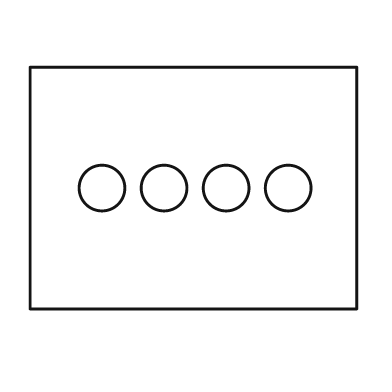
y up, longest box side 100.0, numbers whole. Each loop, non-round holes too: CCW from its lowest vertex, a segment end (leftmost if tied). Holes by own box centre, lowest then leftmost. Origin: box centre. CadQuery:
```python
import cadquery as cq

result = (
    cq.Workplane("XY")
    .moveTo(-50.0, -37.0)
    .lineTo(50.0, -37.0)
    .lineTo(50.0, 37.0)
    .lineTo(-50.0, 37.0)
    .close()
    .moveTo(-28.0, 0.0)
    .circle(7.0)
    .moveTo(-9.0, 0.0)
    .circle(7.0)
    .moveTo(10.0, 0.0)
    .circle(7.0)
    .moveTo(29.0, 0.0)
    .circle(7.0)
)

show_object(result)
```